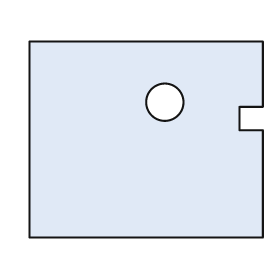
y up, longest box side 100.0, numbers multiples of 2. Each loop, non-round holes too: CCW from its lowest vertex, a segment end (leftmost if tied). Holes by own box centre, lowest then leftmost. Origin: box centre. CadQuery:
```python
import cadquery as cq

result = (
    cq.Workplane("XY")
    .moveTo(-50.0, -42.0)
    .lineTo(50.0, -42.0)
    .lineTo(50.0, 4.0)
    .lineTo(40.0, 4.0)
    .lineTo(40.0, 14.0)
    .lineTo(50.0, 14.0)
    .lineTo(50.0, 42.0)
    .lineTo(-50.0, 42.0)
    .close()
    .moveTo(8.0, 16.0)
    .circle(8.0)
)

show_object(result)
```